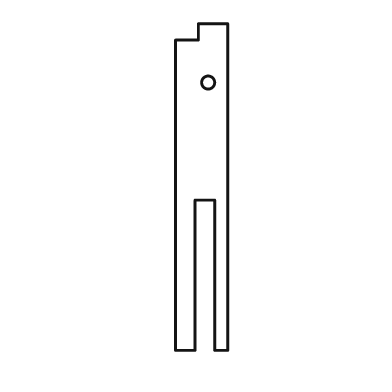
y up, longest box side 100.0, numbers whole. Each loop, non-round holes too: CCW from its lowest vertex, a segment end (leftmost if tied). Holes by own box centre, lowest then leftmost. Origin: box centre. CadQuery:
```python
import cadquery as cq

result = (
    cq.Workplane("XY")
    .moveTo(-8.0, -50.0)
    .lineTo(-2.0, -50.0)
    .lineTo(-2.0, -4.0)
    .lineTo(4.0, -4.0)
    .lineTo(4.0, -50.0)
    .lineTo(8.0, -50.0)
    .lineTo(8.0, 50.0)
    .lineTo(-1.0, 50.0)
    .lineTo(-1.0, 45.0)
    .lineTo(-8.0, 45.0)
    .close()
    .moveTo(2.0, 32.0)
    .circle(2.0)
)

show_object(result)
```